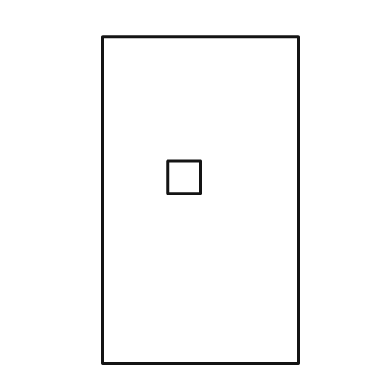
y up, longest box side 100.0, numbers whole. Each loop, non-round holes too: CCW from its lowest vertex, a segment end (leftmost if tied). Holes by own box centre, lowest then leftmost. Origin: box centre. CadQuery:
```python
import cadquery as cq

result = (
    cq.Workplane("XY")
    .moveTo(-30.0, -50.0)
    .lineTo(30.0, -50.0)
    .lineTo(30.0, 50.0)
    .lineTo(-30.0, 50.0)
    .close()
    .moveTo(-10.0, 2.0)
    .lineTo(0.0, 2.0)
    .lineTo(0.0, 12.0)
    .lineTo(-10.0, 12.0)
    .close()
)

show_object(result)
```